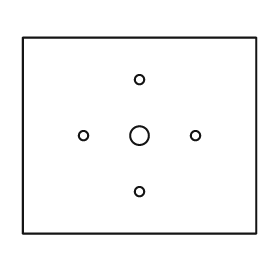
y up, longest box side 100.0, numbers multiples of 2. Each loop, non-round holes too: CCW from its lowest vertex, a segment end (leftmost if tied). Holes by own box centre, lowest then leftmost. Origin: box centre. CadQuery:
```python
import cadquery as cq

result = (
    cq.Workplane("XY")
    .moveTo(-50.0, -42.0)
    .lineTo(50.0, -42.0)
    .lineTo(50.0, 42.0)
    .lineTo(-50.0, 42.0)
    .close()
    .moveTo(0.0, -24.0)
    .circle(2.0)
    .moveTo(-24.0, 0.0)
    .circle(2.0)
    .moveTo(0.0, 0.0)
    .circle(4.0)
    .moveTo(24.0, 0.0)
    .circle(2.0)
    .moveTo(0.0, 24.0)
    .circle(2.0)
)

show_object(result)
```